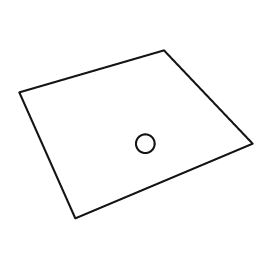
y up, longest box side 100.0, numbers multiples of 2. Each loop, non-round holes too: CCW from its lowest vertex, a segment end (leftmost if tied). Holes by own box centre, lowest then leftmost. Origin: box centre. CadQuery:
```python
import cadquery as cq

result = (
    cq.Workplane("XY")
    .moveTo(-26.0, -36.0)
    .lineTo(50.0, -4.0)
    .lineTo(12.0, 36.0)
    .lineTo(-50.0, 18.0)
    .close()
    .moveTo(4.0, -4.0)
    .circle(4.0)
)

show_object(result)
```